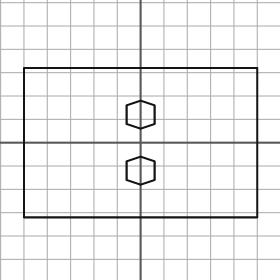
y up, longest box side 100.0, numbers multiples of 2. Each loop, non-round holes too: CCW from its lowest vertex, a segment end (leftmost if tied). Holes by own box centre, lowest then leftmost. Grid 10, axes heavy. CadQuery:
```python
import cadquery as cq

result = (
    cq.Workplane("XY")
    .moveTo(-50.0, -32.0)
    .lineTo(50.0, -32.0)
    .lineTo(50.0, 32.0)
    .lineTo(-50.0, 32.0)
    .close()
    .moveTo(0.0, -18.0)
    .lineTo(6.0, -16.0)
    .lineTo(6.0, -8.0)
    .lineTo(0.0, -6.0)
    .lineTo(-6.0, -8.0)
    .lineTo(-6.0, -16.0)
    .close()
    .moveTo(0.0, 6.0)
    .lineTo(6.0, 8.0)
    .lineTo(6.0, 16.0)
    .lineTo(0.0, 18.0)
    .lineTo(-6.0, 16.0)
    .lineTo(-6.0, 8.0)
    .close()
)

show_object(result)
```